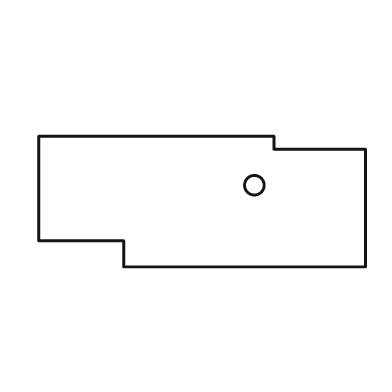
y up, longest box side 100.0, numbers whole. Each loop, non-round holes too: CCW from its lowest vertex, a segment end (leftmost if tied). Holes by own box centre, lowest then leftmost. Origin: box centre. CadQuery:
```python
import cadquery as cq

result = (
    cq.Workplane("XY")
    .moveTo(-24.0, -20.0)
    .lineTo(50.0, -20.0)
    .lineTo(50.0, 16.0)
    .lineTo(22.0, 16.0)
    .lineTo(22.0, 20.0)
    .lineTo(-50.0, 20.0)
    .lineTo(-50.0, -12.0)
    .lineTo(-24.0, -12.0)
    .close()
    .moveTo(16.0, 5.0)
    .circle(3.0)
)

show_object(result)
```